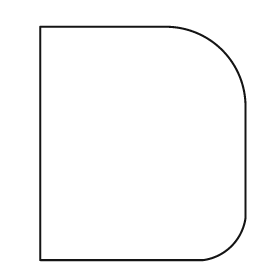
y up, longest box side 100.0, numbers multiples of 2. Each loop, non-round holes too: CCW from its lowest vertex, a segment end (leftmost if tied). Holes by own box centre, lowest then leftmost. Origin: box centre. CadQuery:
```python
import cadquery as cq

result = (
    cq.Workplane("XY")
    .moveTo(-44.0, -50.0)
    .lineTo(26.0, -50.0)
    .threePointArc((38.0, -44.0), (44.0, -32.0))
    .lineTo(44.0, 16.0)
    .threePointArc((34.0, 40.0), (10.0, 50.0))
    .lineTo(-44.0, 50.0)
    .close()
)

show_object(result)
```